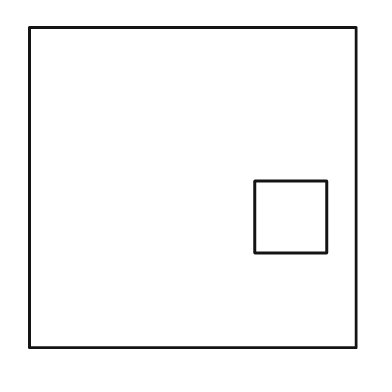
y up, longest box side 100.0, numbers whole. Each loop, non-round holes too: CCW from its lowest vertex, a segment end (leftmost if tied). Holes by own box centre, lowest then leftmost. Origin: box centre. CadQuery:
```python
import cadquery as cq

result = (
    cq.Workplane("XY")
    .moveTo(-50.0, -49.0)
    .lineTo(50.0, -49.0)
    .lineTo(50.0, 49.0)
    .lineTo(-50.0, 49.0)
    .close()
    .moveTo(19.0, -20.0)
    .lineTo(41.0, -20.0)
    .lineTo(41.0, 2.0)
    .lineTo(19.0, 2.0)
    .close()
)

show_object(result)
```